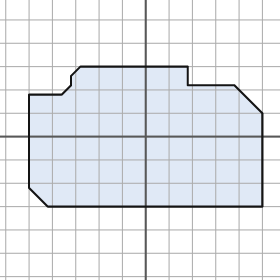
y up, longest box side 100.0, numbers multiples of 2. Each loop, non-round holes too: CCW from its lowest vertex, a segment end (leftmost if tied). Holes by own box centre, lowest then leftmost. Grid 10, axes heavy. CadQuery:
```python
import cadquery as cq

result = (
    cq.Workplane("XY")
    .moveTo(-42.0, -30.0)
    .lineTo(50.0, -30.0)
    .lineTo(50.0, 10.0)
    .lineTo(38.0, 22.0)
    .lineTo(18.0, 22.0)
    .lineTo(18.0, 30.0)
    .lineTo(-28.0, 30.0)
    .lineTo(-32.0, 26.0)
    .lineTo(-32.0, 22.0)
    .lineTo(-36.0, 18.0)
    .lineTo(-50.0, 18.0)
    .lineTo(-50.0, -22.0)
    .close()
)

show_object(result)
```